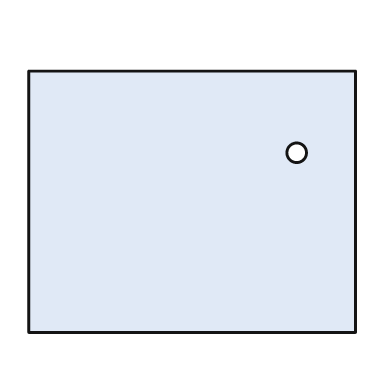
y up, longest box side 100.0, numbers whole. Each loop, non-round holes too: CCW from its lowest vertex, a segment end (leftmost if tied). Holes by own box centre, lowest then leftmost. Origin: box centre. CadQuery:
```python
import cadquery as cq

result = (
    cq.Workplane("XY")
    .moveTo(-50.0, -40.0)
    .lineTo(50.0, -40.0)
    .lineTo(50.0, 40.0)
    .lineTo(-50.0, 40.0)
    .close()
    .moveTo(32.0, 15.0)
    .circle(3.0)
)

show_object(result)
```